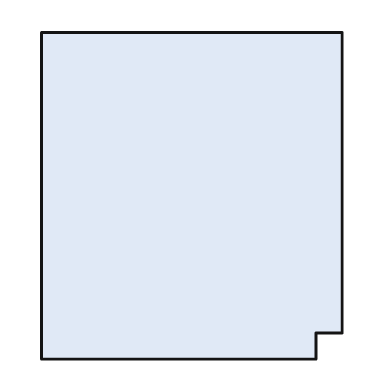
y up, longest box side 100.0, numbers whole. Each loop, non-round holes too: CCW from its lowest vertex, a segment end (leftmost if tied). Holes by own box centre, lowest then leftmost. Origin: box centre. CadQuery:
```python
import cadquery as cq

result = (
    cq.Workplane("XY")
    .moveTo(-46.0, -50.0)
    .lineTo(38.0, -50.0)
    .lineTo(38.0, -42.0)
    .lineTo(46.0, -42.0)
    .lineTo(46.0, 50.0)
    .lineTo(-46.0, 50.0)
    .close()
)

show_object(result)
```